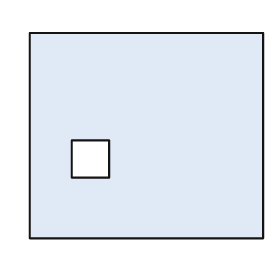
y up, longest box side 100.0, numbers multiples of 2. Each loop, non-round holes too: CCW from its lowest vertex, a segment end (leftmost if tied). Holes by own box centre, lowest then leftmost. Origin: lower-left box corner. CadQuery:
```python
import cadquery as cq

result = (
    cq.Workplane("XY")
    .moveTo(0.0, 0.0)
    .lineTo(100.0, 0.0)
    .lineTo(100.0, 88.0)
    .lineTo(0.0, 88.0)
    .close()
    .moveTo(18.0, 26.0)
    .lineTo(34.0, 26.0)
    .lineTo(34.0, 42.0)
    .lineTo(18.0, 42.0)
    .close()
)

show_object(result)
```